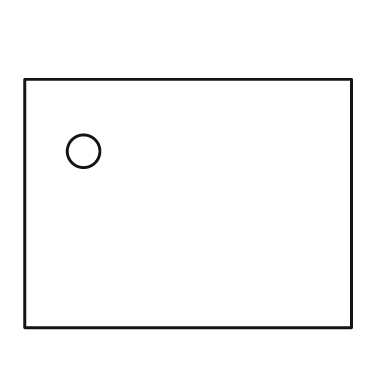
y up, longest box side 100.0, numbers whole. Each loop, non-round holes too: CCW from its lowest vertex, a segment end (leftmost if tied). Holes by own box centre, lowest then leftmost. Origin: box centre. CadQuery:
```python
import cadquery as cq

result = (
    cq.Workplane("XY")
    .moveTo(-50.0, -38.0)
    .lineTo(50.0, -38.0)
    .lineTo(50.0, 38.0)
    .lineTo(-50.0, 38.0)
    .close()
    .moveTo(-32.0, 16.0)
    .circle(5.0)
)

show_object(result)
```